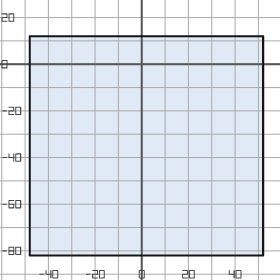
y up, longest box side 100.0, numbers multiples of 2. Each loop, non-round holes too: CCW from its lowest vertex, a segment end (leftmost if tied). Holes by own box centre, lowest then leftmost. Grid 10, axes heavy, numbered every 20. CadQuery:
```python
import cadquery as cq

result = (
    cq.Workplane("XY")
    .moveTo(-48.0, -82.0)
    .lineTo(52.0, -82.0)
    .lineTo(52.0, 12.0)
    .lineTo(-48.0, 12.0)
    .close()
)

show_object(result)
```